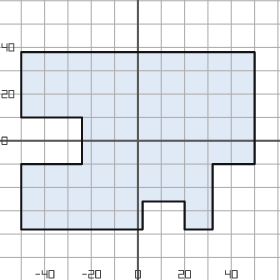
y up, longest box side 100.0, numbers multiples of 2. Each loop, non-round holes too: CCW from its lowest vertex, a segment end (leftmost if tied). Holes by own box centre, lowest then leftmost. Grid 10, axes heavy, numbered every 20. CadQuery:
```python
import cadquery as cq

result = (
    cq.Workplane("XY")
    .moveTo(-50.0, -38.0)
    .lineTo(2.0, -38.0)
    .lineTo(2.0, -26.0)
    .lineTo(20.0, -26.0)
    .lineTo(20.0, -38.0)
    .lineTo(32.0, -38.0)
    .lineTo(32.0, -10.0)
    .lineTo(50.0, -10.0)
    .lineTo(50.0, 38.0)
    .lineTo(-50.0, 38.0)
    .lineTo(-50.0, 10.0)
    .lineTo(-24.0, 10.0)
    .lineTo(-24.0, -10.0)
    .lineTo(-50.0, -10.0)
    .close()
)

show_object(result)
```